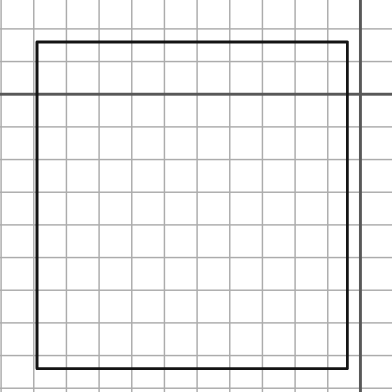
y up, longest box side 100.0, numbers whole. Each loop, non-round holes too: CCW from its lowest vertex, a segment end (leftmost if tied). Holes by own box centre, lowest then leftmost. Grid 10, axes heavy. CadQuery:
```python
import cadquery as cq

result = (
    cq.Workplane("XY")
    .moveTo(-99.0, -84.0)
    .lineTo(-4.0, -84.0)
    .lineTo(-4.0, 16.0)
    .lineTo(-99.0, 16.0)
    .close()
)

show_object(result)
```